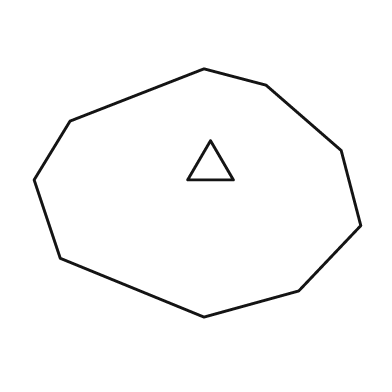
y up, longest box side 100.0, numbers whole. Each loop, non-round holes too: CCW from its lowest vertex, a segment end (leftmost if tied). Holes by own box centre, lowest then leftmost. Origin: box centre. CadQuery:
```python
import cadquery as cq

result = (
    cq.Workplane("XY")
    .moveTo(2.0, -38.0)
    .lineTo(31.0, -30.0)
    .lineTo(50.0, -10.0)
    .lineTo(44.0, 13.0)
    .lineTo(21.0, 33.0)
    .lineTo(2.0, 38.0)
    .lineTo(-39.0, 22.0)
    .lineTo(-50.0, 4.0)
    .lineTo(-42.0, -20.0)
    .close()
    .moveTo(-3.0, 4.0)
    .lineTo(11.0, 4.0)
    .lineTo(4.0, 16.0)
    .close()
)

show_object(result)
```